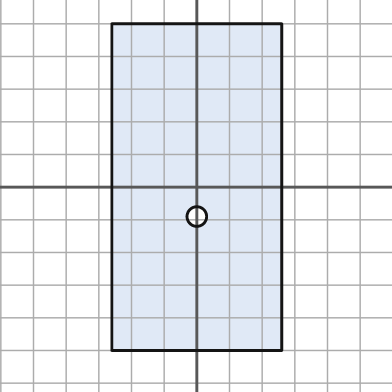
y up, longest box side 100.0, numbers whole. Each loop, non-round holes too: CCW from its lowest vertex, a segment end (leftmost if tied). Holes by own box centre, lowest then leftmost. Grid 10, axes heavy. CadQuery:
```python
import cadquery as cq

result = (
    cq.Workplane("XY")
    .moveTo(-26.0, -50.0)
    .lineTo(26.0, -50.0)
    .lineTo(26.0, 50.0)
    .lineTo(-26.0, 50.0)
    .close()
    .moveTo(0.0, -9.0)
    .circle(3.0)
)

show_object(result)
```